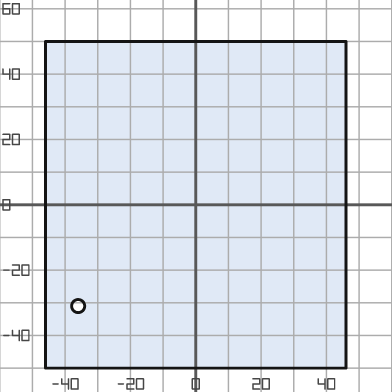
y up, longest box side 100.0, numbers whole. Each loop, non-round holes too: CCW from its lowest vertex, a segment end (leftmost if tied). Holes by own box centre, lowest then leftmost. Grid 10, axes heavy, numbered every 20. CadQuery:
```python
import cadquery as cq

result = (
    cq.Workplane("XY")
    .moveTo(-46.0, -50.0)
    .lineTo(46.0, -50.0)
    .lineTo(46.0, 50.0)
    .lineTo(-46.0, 50.0)
    .close()
    .moveTo(-36.0, -31.0)
    .circle(2.0)
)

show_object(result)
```